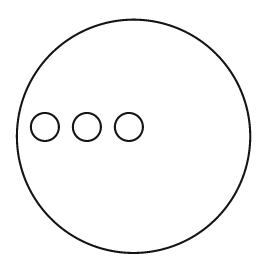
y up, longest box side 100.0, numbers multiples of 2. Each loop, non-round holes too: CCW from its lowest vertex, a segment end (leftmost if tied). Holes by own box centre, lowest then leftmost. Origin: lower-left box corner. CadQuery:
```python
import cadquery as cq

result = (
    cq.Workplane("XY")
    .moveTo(50.0, 50.0)
    .circle(50.0)
    .moveTo(12.0, 54.0)
    .circle(6.0)
    .moveTo(30.0, 54.0)
    .circle(6.0)
    .moveTo(48.0, 54.0)
    .circle(6.0)
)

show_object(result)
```